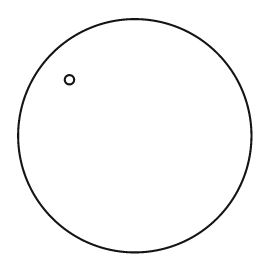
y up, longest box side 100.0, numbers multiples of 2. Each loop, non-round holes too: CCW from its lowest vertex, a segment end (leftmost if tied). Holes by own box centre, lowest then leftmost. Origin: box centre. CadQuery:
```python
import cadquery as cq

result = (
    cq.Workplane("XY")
    .moveTo(0.0, 0.0)
    .circle(50.0)
    .moveTo(-28.0, 24.0)
    .circle(2.0)
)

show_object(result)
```